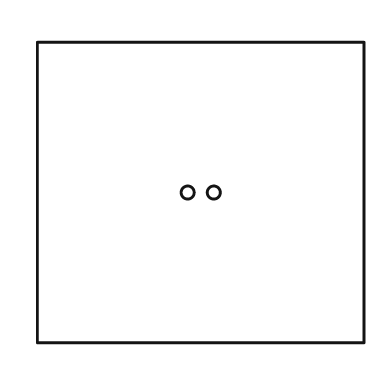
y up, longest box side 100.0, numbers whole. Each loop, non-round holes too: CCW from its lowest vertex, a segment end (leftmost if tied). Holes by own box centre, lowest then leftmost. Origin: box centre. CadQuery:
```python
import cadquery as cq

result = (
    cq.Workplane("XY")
    .moveTo(-50.0, -46.0)
    .lineTo(50.0, -46.0)
    .lineTo(50.0, 46.0)
    .lineTo(-50.0, 46.0)
    .close()
    .moveTo(-4.0, 0.0)
    .circle(2.0)
    .moveTo(4.0, 0.0)
    .circle(2.0)
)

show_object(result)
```